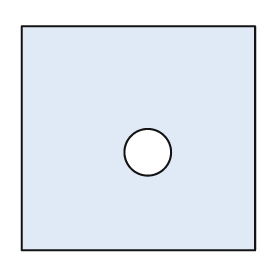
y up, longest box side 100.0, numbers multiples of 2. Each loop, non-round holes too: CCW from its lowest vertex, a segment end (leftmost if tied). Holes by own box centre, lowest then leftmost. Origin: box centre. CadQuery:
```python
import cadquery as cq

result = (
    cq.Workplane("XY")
    .moveTo(-50.0, -48.0)
    .lineTo(50.0, -48.0)
    .lineTo(50.0, 48.0)
    .lineTo(-50.0, 48.0)
    .close()
    .moveTo(4.0, -6.0)
    .circle(10.0)
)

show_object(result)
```